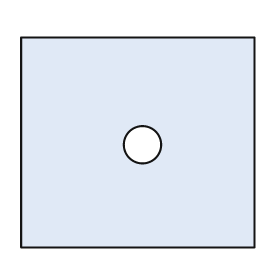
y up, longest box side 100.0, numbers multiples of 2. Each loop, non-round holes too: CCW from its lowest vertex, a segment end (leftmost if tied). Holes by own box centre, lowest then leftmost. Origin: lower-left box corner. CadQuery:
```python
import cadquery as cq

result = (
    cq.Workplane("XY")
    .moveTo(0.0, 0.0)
    .lineTo(100.0, 0.0)
    .lineTo(100.0, 90.0)
    .lineTo(0.0, 90.0)
    .close()
    .moveTo(52.0, 44.0)
    .circle(8.0)
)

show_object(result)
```